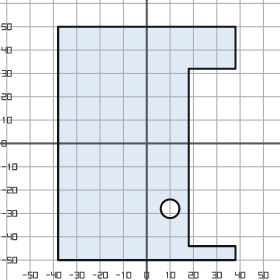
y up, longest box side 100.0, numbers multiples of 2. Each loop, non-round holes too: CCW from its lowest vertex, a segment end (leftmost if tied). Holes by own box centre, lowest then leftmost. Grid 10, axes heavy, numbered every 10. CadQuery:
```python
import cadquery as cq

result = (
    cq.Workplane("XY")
    .moveTo(-38.0, -50.0)
    .lineTo(38.0, -50.0)
    .lineTo(38.0, -44.0)
    .lineTo(18.0, -44.0)
    .lineTo(18.0, 32.0)
    .lineTo(38.0, 32.0)
    .lineTo(38.0, 50.0)
    .lineTo(-38.0, 50.0)
    .close()
    .moveTo(10.0, -28.0)
    .circle(4.0)
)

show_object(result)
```